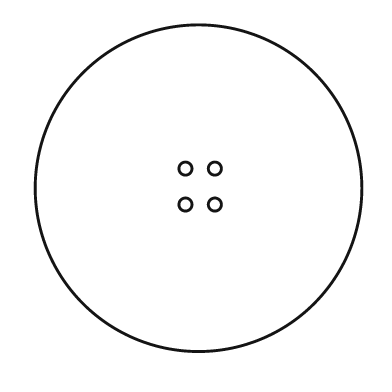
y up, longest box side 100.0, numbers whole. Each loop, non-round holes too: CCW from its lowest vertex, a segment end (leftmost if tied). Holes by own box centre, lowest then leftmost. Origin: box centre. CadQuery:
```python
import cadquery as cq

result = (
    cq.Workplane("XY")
    .moveTo(0.0, 0.0)
    .circle(50.0)
    .moveTo(-4.0, -5.0)
    .circle(2.0)
    .moveTo(5.0, -5.0)
    .circle(2.0)
    .moveTo(-4.0, 6.0)
    .circle(2.0)
    .moveTo(5.0, 6.0)
    .circle(2.0)
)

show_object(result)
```